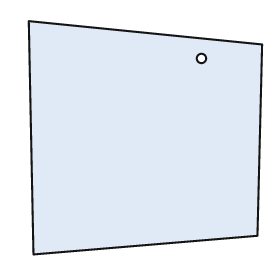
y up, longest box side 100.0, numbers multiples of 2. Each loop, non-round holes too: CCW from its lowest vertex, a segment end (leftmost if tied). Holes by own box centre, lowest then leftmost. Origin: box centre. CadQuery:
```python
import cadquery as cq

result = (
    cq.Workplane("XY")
    .moveTo(-48.0, -50.0)
    .lineTo(48.0, -42.0)
    .lineTo(50.0, 40.0)
    .lineTo(-50.0, 50.0)
    .close()
    .moveTo(24.0, 34.0)
    .circle(2.0)
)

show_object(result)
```